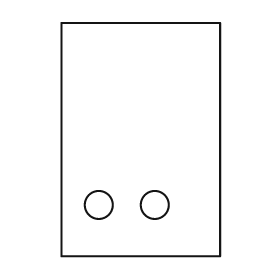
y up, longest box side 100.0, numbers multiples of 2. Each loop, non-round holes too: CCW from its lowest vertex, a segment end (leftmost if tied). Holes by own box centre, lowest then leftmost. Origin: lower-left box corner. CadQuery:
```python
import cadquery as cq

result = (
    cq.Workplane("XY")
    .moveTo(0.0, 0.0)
    .lineTo(68.0, 0.0)
    .lineTo(68.0, 100.0)
    .lineTo(0.0, 100.0)
    .close()
    .moveTo(16.0, 22.0)
    .circle(6.0)
    .moveTo(40.0, 22.0)
    .circle(6.0)
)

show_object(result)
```